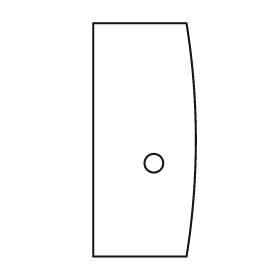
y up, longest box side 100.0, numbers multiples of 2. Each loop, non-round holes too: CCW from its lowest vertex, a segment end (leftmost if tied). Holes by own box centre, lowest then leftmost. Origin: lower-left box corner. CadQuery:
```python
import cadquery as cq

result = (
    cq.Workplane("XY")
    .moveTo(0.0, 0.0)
    .lineTo(40.0, 0.0)
    .threePointArc((44.0, 50.0), (40.0, 100.0))
    .lineTo(0.0, 100.0)
    .close()
    .moveTo(26.0, 40.0)
    .circle(4.0)
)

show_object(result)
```